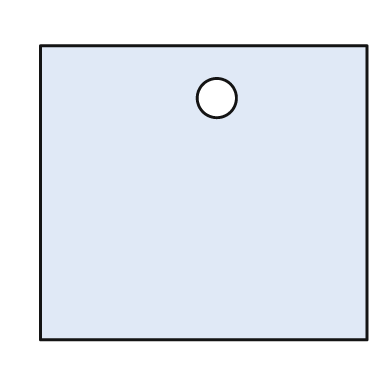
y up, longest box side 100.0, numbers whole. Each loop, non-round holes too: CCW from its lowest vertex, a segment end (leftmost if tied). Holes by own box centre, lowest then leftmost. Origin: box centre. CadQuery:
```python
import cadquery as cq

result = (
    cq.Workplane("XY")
    .moveTo(-50.0, -45.0)
    .lineTo(50.0, -45.0)
    .lineTo(50.0, 45.0)
    .lineTo(-50.0, 45.0)
    .close()
    .moveTo(4.0, 29.0)
    .circle(6.0)
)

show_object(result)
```